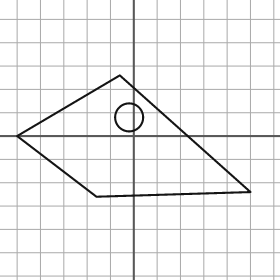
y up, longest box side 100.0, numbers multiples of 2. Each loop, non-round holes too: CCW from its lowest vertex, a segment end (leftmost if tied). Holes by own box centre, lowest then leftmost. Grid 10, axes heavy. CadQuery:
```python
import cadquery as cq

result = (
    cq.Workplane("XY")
    .moveTo(-16.0, -26.0)
    .lineTo(50.0, -24.0)
    .lineTo(-6.0, 26.0)
    .lineTo(-50.0, 0.0)
    .close()
    .moveTo(-2.0, 8.0)
    .circle(6.0)
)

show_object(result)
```